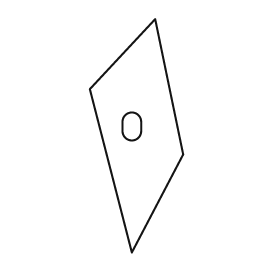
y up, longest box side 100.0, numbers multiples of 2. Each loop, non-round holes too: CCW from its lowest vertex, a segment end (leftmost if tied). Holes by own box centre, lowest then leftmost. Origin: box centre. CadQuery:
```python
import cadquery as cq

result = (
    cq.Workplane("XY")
    .moveTo(-2.0, -50.0)
    .lineTo(20.0, -8.0)
    .lineTo(8.0, 50.0)
    .lineTo(-20.0, 20.0)
    .close()
    .moveTo(-6.0, 2.0)
    .threePointArc((-2.0, -2.0), (2.0, 2.0))
    .lineTo(2.0, 6.0)
    .threePointArc((-2.0, 10.0), (-6.0, 6.0))
    .close()
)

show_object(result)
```